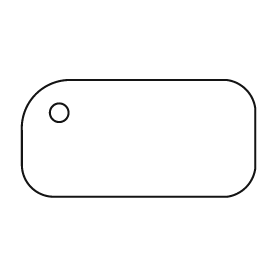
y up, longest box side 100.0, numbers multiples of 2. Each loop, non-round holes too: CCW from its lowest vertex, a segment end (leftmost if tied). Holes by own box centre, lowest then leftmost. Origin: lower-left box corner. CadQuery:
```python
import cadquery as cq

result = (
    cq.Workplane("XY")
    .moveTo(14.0, 0.0)
    .lineTo(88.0, 0.0)
    .threePointArc((96.0, 4.0), (100.0, 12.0))
    .lineTo(100.0, 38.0)
    .threePointArc((96.0, 46.0), (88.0, 50.0))
    .lineTo(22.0, 50.0)
    .threePointArc((6.0, 44.0), (0.0, 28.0))
    .lineTo(0.0, 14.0)
    .threePointArc((4.0, 4.0), (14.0, 0.0))
    .close()
    .moveTo(16.0, 36.0)
    .circle(4.0)
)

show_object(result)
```